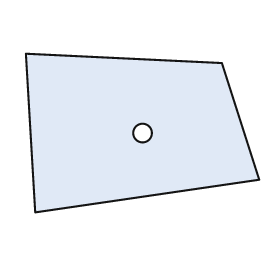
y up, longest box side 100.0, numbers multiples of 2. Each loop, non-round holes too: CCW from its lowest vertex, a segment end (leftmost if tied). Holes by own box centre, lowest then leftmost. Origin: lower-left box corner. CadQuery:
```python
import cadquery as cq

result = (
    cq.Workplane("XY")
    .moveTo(4.0, 0.0)
    .lineTo(100.0, 14.0)
    .lineTo(84.0, 64.0)
    .lineTo(0.0, 68.0)
    .close()
    .moveTo(50.0, 34.0)
    .circle(4.0)
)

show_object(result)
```